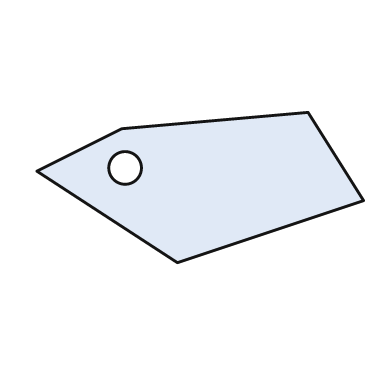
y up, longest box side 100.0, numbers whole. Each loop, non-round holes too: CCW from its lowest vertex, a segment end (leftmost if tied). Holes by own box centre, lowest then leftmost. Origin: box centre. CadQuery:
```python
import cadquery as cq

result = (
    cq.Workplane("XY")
    .moveTo(-7.0, -23.0)
    .lineTo(50.0, -4.0)
    .lineTo(33.0, 23.0)
    .lineTo(-24.0, 18.0)
    .lineTo(-50.0, 5.0)
    .close()
    .moveTo(-23.0, 6.0)
    .circle(5.0)
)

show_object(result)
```